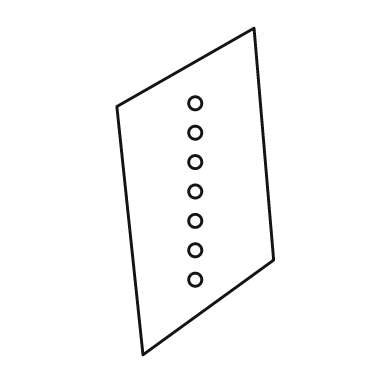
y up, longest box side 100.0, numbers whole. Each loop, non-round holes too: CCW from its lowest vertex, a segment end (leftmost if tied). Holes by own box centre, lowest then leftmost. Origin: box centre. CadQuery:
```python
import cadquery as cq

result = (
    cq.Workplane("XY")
    .moveTo(-16.0, -50.0)
    .lineTo(24.0, -21.0)
    .lineTo(18.0, 50.0)
    .lineTo(-24.0, 26.0)
    .close()
    .moveTo(0.0, -27.0)
    .circle(2.0)
    .moveTo(0.0, -18.0)
    .circle(2.0)
    .moveTo(0.0, -9.0)
    .circle(2.0)
    .moveTo(0.0, 0.0)
    .circle(2.0)
    .moveTo(0.0, 9.0)
    .circle(2.0)
    .moveTo(0.0, 18.0)
    .circle(2.0)
    .moveTo(0.0, 27.0)
    .circle(2.0)
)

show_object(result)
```